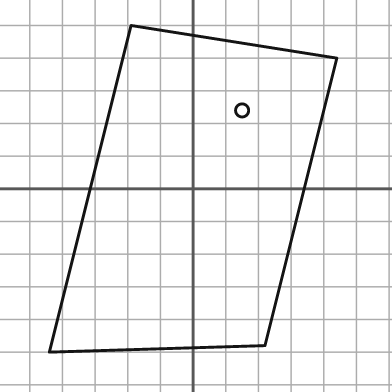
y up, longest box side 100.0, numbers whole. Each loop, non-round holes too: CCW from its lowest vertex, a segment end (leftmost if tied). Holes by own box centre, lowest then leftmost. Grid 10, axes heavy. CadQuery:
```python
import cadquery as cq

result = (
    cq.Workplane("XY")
    .moveTo(-44.0, -50.0)
    .lineTo(22.0, -48.0)
    .lineTo(44.0, 40.0)
    .lineTo(-19.0, 50.0)
    .close()
    .moveTo(15.0, 24.0)
    .circle(2.0)
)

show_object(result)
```